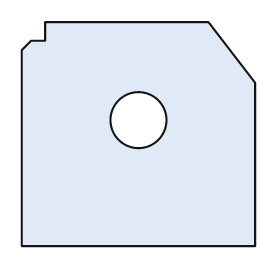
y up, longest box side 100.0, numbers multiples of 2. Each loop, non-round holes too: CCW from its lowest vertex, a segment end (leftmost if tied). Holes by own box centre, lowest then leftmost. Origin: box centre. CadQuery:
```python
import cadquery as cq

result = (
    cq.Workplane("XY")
    .moveTo(-50.0, -48.0)
    .lineTo(50.0, -48.0)
    .lineTo(50.0, 22.0)
    .lineTo(30.0, 48.0)
    .lineTo(-40.0, 48.0)
    .lineTo(-40.0, 40.0)
    .lineTo(-46.0, 40.0)
    .lineTo(-50.0, 36.0)
    .close()
    .moveTo(0.0, 6.0)
    .circle(12.0)
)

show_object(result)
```